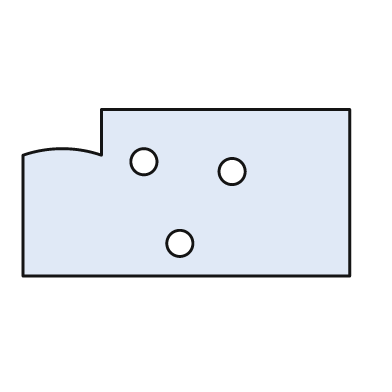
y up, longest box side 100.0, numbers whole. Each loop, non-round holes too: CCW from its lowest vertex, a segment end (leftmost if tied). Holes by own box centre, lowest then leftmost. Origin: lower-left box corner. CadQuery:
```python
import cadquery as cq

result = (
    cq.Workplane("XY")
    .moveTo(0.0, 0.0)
    .lineTo(100.0, 0.0)
    .lineTo(100.0, 51.0)
    .lineTo(24.0, 51.0)
    .lineTo(24.0, 37.0)
    .threePointArc((12.0, 39.0), (0.0, 37.0))
    .close()
    .moveTo(48.0, 10.0)
    .circle(4.0)
    .moveTo(64.0, 32.0)
    .circle(4.0)
    .moveTo(37.0, 35.0)
    .circle(4.0)
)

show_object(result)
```